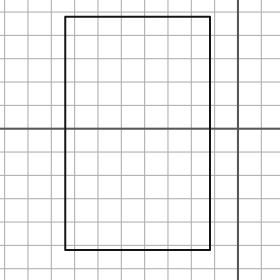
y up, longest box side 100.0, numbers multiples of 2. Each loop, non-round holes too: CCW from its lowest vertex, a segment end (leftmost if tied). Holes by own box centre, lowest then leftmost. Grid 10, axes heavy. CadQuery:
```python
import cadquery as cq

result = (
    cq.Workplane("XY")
    .moveTo(-74.0, -52.0)
    .lineTo(-12.0, -52.0)
    .lineTo(-12.0, 48.0)
    .lineTo(-74.0, 48.0)
    .close()
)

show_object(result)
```